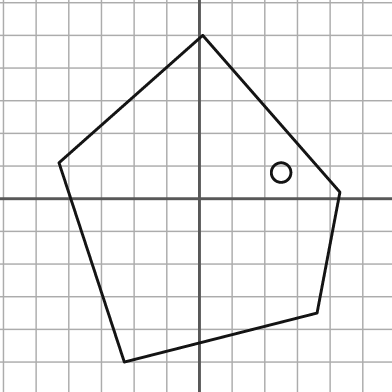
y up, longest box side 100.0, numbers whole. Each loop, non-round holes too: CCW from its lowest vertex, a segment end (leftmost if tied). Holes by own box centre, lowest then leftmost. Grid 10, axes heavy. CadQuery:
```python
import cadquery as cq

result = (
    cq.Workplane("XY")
    .moveTo(-23.0, -50.0)
    .lineTo(36.0, -35.0)
    .lineTo(43.0, 2.0)
    .lineTo(1.0, 50.0)
    .lineTo(-43.0, 11.0)
    .close()
    .moveTo(25.0, 8.0)
    .circle(3.0)
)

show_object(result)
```